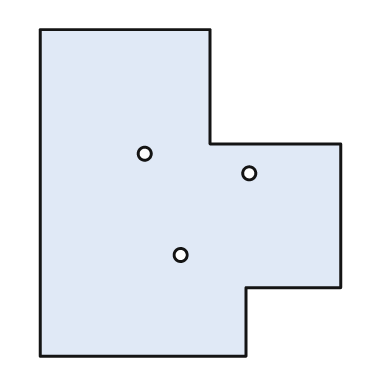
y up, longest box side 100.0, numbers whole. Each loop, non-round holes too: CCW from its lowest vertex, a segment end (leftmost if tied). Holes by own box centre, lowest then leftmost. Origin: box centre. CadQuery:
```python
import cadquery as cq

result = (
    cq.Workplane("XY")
    .moveTo(-46.0, -50.0)
    .lineTo(17.0, -50.0)
    .lineTo(17.0, -29.0)
    .lineTo(46.0, -29.0)
    .lineTo(46.0, 15.0)
    .lineTo(6.0, 15.0)
    .lineTo(6.0, 50.0)
    .lineTo(-46.0, 50.0)
    .close()
    .moveTo(-3.0, -19.0)
    .circle(2.0)
    .moveTo(18.0, 6.0)
    .circle(2.0)
    .moveTo(-14.0, 12.0)
    .circle(2.0)
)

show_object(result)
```